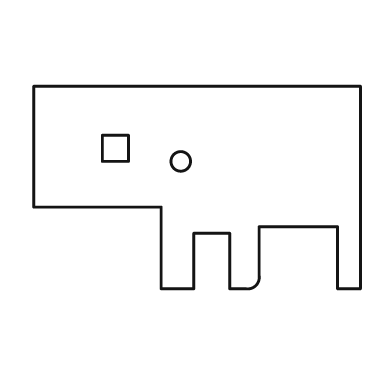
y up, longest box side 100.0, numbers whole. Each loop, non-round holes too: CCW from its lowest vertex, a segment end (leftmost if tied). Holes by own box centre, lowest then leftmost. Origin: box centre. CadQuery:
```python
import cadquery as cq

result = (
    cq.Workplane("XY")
    .moveTo(-11.0, -31.0)
    .lineTo(-1.0, -31.0)
    .lineTo(-1.0, -14.0)
    .lineTo(10.0, -14.0)
    .lineTo(10.0, -31.0)
    .lineTo(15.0, -31.0)
    .threePointArc((18.0, -30.0), (19.0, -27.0))
    .lineTo(19.0, -12.0)
    .lineTo(43.0, -12.0)
    .lineTo(43.0, -31.0)
    .lineTo(50.0, -31.0)
    .lineTo(50.0, 31.0)
    .lineTo(-50.0, 31.0)
    .lineTo(-50.0, -6.0)
    .lineTo(-11.0, -6.0)
    .close()
    .moveTo(-5.0, 8.0)
    .circle(3.0)
    .moveTo(-29.0, 8.0)
    .lineTo(-21.0, 8.0)
    .lineTo(-21.0, 16.0)
    .lineTo(-29.0, 16.0)
    .close()
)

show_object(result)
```